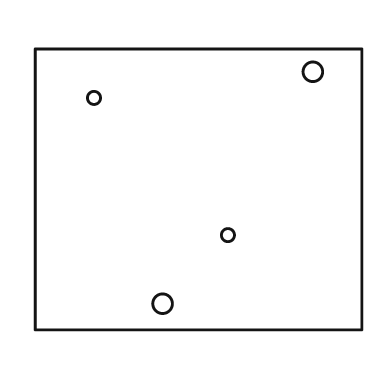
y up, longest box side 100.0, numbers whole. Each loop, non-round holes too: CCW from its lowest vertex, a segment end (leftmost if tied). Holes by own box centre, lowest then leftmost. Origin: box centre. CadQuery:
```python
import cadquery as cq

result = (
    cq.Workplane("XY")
    .moveTo(-50.0, -43.0)
    .lineTo(50.0, -43.0)
    .lineTo(50.0, 43.0)
    .lineTo(-50.0, 43.0)
    .close()
    .moveTo(-11.0, -35.0)
    .circle(3.0)
    .moveTo(9.0, -14.0)
    .circle(2.0)
    .moveTo(-32.0, 28.0)
    .circle(2.0)
    .moveTo(35.0, 36.0)
    .circle(3.0)
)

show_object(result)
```